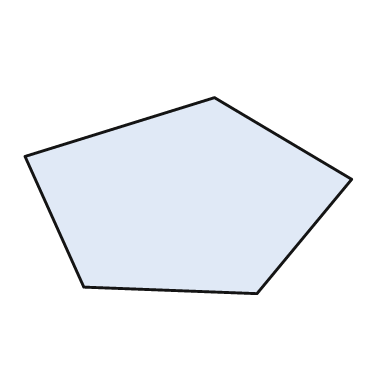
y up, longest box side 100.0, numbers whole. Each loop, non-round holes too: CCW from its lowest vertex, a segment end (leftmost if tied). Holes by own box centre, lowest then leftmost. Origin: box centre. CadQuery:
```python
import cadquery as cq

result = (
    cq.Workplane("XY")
    .moveTo(21.0, -30.0)
    .lineTo(50.0, 5.0)
    .lineTo(8.0, 30.0)
    .lineTo(-50.0, 12.0)
    .lineTo(-32.0, -28.0)
    .close()
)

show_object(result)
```